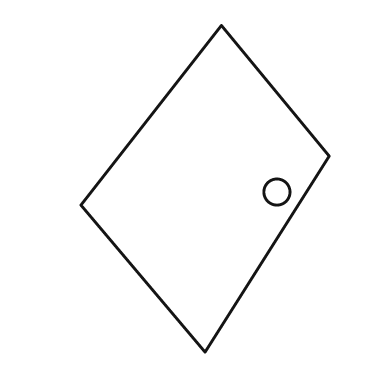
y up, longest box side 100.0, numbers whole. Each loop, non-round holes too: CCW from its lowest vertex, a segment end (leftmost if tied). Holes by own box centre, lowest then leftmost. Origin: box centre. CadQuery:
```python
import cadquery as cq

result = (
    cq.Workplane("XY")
    .moveTo(0.0, -50.0)
    .lineTo(38.0, 10.0)
    .lineTo(5.0, 50.0)
    .lineTo(-38.0, -5.0)
    .close()
    .moveTo(22.0, -1.0)
    .circle(4.0)
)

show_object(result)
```